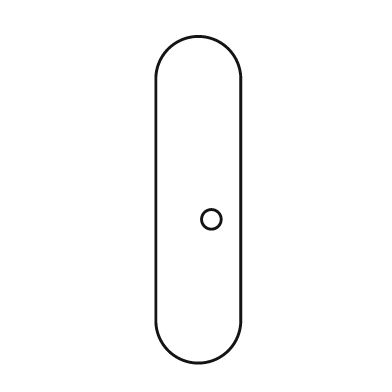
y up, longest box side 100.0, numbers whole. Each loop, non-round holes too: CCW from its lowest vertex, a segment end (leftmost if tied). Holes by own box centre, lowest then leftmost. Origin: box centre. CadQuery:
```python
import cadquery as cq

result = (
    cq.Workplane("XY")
    .moveTo(-13.0, -37.0)
    .threePointArc((0.0, -50.0), (13.0, -37.0))
    .lineTo(13.0, 37.0)
    .threePointArc((0.0, 50.0), (-13.0, 37.0))
    .close()
    .moveTo(4.0, -6.0)
    .circle(3.0)
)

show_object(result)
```